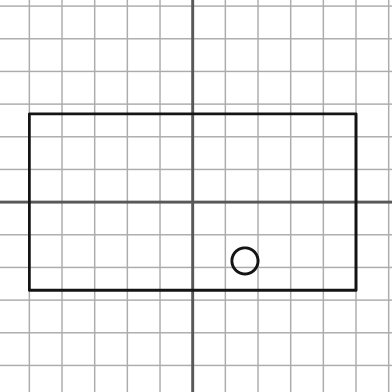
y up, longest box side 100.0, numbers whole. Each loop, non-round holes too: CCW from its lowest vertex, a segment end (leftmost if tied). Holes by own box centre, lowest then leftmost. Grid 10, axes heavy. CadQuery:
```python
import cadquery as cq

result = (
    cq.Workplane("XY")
    .moveTo(-50.0, -27.0)
    .lineTo(50.0, -27.0)
    .lineTo(50.0, 27.0)
    .lineTo(-50.0, 27.0)
    .close()
    .moveTo(16.0, -18.0)
    .circle(4.0)
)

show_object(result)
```